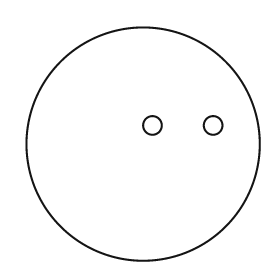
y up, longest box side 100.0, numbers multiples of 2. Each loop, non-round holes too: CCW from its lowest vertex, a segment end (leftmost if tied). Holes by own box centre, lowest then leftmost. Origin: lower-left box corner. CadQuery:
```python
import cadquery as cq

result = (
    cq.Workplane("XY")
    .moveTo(50.0, 50.0)
    .circle(50.0)
    .moveTo(54.0, 58.0)
    .circle(4.0)
    .moveTo(80.0, 58.0)
    .circle(4.0)
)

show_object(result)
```